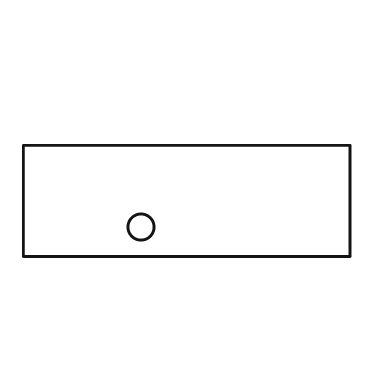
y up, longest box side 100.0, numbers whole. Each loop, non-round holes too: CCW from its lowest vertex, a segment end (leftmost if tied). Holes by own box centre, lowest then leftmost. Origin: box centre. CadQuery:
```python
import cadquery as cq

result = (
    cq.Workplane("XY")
    .moveTo(-50.0, -17.0)
    .lineTo(50.0, -17.0)
    .lineTo(50.0, 17.0)
    .lineTo(-50.0, 17.0)
    .close()
    .moveTo(-14.0, -8.0)
    .circle(4.0)
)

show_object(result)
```